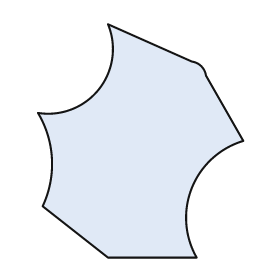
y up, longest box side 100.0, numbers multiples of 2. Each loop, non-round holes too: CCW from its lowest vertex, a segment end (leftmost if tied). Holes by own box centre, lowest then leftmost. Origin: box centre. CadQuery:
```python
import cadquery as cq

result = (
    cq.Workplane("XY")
    .moveTo(-14.0, -50.0)
    .lineTo(24.0, -50.0)
    .threePointArc((22.0, -20.0), (44.0, 0.0))
    .lineTo(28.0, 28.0)
    .threePointArc((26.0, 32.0), (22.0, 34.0))
    .lineTo(-14.0, 50.0)
    .threePointArc((-18.0, 22.0), (-44.0, 12.0))
    .threePointArc((-38.0, -8.0), (-42.0, -28.0))
    .close()
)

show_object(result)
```